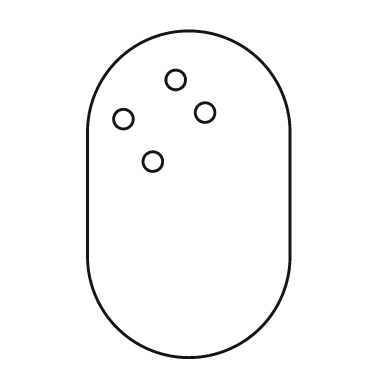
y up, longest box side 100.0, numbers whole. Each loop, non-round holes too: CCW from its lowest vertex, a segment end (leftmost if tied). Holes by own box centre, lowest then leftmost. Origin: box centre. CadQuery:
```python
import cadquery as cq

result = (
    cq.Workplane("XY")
    .moveTo(-31.0, -19.0)
    .threePointArc((0.0, -50.0), (31.0, -19.0))
    .lineTo(31.0, 19.0)
    .threePointArc((0.0, 50.0), (-31.0, 19.0))
    .close()
    .moveTo(-11.0, 10.0)
    .circle(3.0)
    .moveTo(-20.0, 23.0)
    .circle(3.0)
    .moveTo(5.0, 25.0)
    .circle(3.0)
    .moveTo(-4.0, 35.0)
    .circle(3.0)
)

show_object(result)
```